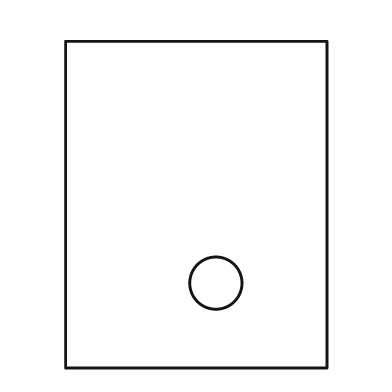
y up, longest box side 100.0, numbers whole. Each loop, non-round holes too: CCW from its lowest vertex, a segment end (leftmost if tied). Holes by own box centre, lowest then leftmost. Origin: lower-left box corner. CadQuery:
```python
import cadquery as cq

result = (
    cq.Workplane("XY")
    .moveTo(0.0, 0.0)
    .lineTo(80.0, 0.0)
    .lineTo(80.0, 100.0)
    .lineTo(0.0, 100.0)
    .close()
    .moveTo(46.0, 26.0)
    .circle(8.0)
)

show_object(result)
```